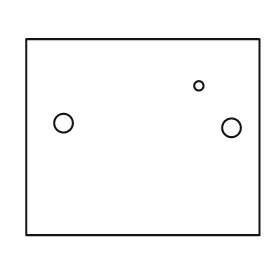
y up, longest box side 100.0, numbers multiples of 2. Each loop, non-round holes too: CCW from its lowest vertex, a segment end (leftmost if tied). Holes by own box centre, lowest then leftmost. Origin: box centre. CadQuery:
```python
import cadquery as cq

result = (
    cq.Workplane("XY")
    .moveTo(-50.0, -42.0)
    .lineTo(50.0, -42.0)
    .lineTo(50.0, 42.0)
    .lineTo(-50.0, 42.0)
    .close()
    .moveTo(38.0, 4.0)
    .circle(4.0)
    .moveTo(-34.0, 6.0)
    .circle(4.0)
    .moveTo(24.0, 22.0)
    .circle(2.0)
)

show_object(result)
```